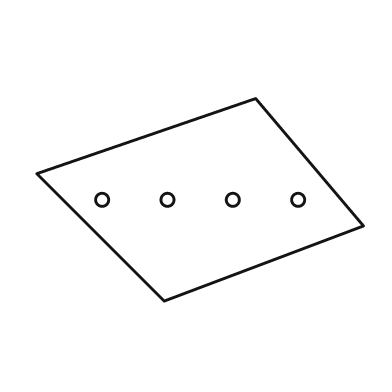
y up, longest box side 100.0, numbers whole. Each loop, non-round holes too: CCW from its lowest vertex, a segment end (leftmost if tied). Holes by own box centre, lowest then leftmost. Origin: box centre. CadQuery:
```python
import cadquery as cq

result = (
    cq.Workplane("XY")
    .moveTo(-11.0, -31.0)
    .lineTo(50.0, -8.0)
    .lineTo(17.0, 31.0)
    .lineTo(-50.0, 8.0)
    .close()
    .moveTo(-30.0, 0.0)
    .circle(2.0)
    .moveTo(-10.0, 0.0)
    .circle(2.0)
    .moveTo(10.0, 0.0)
    .circle(2.0)
    .moveTo(30.0, 0.0)
    .circle(2.0)
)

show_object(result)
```